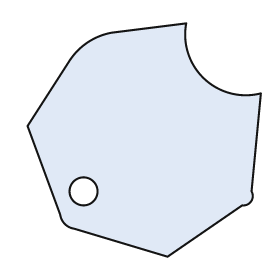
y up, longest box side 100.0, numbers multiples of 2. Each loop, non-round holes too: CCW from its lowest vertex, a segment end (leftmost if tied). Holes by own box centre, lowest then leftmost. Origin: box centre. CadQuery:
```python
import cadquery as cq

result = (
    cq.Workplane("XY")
    .moveTo(10.0, -50.0)
    .lineTo(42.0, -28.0)
    .threePointArc((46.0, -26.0), (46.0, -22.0))
    .lineTo(50.0, 20.0)
    .threePointArc((26.0, 26.0), (18.0, 50.0))
    .lineTo(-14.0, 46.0)
    .threePointArc((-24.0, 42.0), (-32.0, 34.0))
    .lineTo(-50.0, 6.0)
    .lineTo(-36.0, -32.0)
    .threePointArc((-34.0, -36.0), (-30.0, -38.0))
    .close()
    .moveTo(-26.0, -22.0)
    .circle(6.0)
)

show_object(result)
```